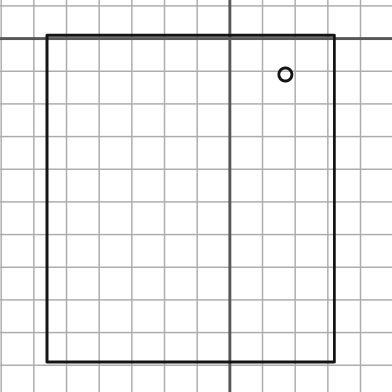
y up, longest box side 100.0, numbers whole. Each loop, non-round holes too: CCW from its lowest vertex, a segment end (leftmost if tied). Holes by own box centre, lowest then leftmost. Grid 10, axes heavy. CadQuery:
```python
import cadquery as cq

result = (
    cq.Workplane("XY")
    .moveTo(-56.0, -99.0)
    .lineTo(32.0, -99.0)
    .lineTo(32.0, 1.0)
    .lineTo(-56.0, 1.0)
    .close()
    .moveTo(17.0, -11.0)
    .circle(2.0)
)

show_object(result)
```